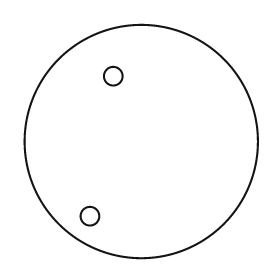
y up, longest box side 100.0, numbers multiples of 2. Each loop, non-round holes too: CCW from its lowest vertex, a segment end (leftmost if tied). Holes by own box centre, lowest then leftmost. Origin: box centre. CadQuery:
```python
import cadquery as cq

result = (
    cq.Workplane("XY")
    .moveTo(0.0, 0.0)
    .circle(50.0)
    .moveTo(-22.0, -32.0)
    .circle(4.0)
    .moveTo(-12.0, 28.0)
    .circle(4.0)
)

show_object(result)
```